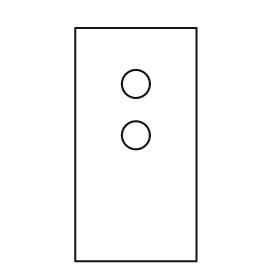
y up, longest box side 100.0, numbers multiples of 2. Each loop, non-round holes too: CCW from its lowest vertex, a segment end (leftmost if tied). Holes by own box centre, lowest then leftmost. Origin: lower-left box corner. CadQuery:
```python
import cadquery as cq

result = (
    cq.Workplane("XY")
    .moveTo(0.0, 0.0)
    .lineTo(52.0, 0.0)
    .lineTo(52.0, 100.0)
    .lineTo(0.0, 100.0)
    .close()
    .moveTo(26.0, 54.0)
    .circle(6.0)
    .moveTo(26.0, 76.0)
    .circle(6.0)
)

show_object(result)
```